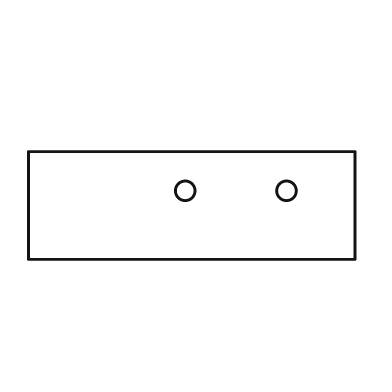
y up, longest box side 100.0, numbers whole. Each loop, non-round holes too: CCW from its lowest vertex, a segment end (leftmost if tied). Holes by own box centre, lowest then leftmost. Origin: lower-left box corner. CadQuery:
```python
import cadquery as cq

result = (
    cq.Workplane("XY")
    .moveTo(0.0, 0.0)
    .lineTo(100.0, 0.0)
    .lineTo(100.0, 33.0)
    .lineTo(0.0, 33.0)
    .close()
    .moveTo(48.0, 21.0)
    .circle(3.0)
    .moveTo(79.0, 21.0)
    .circle(3.0)
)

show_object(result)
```